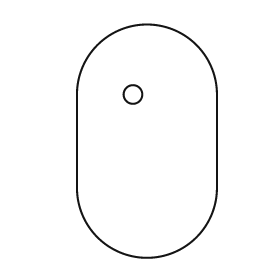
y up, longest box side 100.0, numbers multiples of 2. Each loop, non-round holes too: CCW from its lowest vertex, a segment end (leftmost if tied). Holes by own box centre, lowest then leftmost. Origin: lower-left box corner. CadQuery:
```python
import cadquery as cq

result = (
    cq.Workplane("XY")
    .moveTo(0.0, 30.0)
    .threePointArc((30.0, 0.0), (60.0, 30.0))
    .lineTo(60.0, 70.0)
    .threePointArc((30.0, 100.0), (0.0, 70.0))
    .close()
    .moveTo(24.0, 70.0)
    .circle(4.0)
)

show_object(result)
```